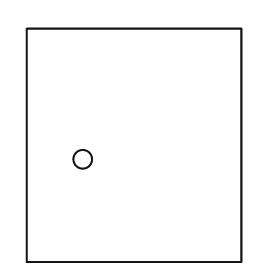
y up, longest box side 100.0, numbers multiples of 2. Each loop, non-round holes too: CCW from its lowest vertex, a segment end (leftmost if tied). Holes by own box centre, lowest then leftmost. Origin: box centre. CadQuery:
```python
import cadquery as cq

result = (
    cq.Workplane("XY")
    .moveTo(-46.0, -50.0)
    .lineTo(46.0, -50.0)
    .lineTo(46.0, 50.0)
    .lineTo(-46.0, 50.0)
    .close()
    .moveTo(-22.0, -6.0)
    .circle(4.0)
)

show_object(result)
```